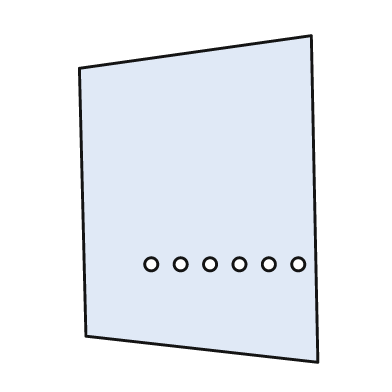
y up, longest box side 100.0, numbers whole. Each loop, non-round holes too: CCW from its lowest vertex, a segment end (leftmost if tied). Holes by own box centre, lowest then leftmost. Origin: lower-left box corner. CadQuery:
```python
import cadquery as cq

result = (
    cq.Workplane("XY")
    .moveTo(73.0, 0.0)
    .lineTo(71.0, 100.0)
    .lineTo(0.0, 90.0)
    .lineTo(2.0, 8.0)
    .close()
    .moveTo(22.0, 30.0)
    .circle(2.0)
    .moveTo(31.0, 30.0)
    .circle(2.0)
    .moveTo(40.0, 30.0)
    .circle(2.0)
    .moveTo(49.0, 30.0)
    .circle(2.0)
    .moveTo(58.0, 30.0)
    .circle(2.0)
    .moveTo(67.0, 30.0)
    .circle(2.0)
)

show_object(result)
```